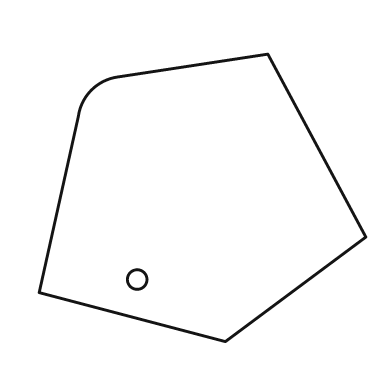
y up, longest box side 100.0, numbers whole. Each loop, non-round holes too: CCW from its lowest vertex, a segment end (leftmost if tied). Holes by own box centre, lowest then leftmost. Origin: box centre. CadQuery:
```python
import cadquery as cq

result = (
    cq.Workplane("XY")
    .moveTo(7.0, -44.0)
    .lineTo(50.0, -12.0)
    .lineTo(20.0, 44.0)
    .lineTo(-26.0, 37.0)
    .threePointArc((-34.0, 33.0), (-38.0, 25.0))
    .lineTo(-50.0, -29.0)
    .close()
    .moveTo(-20.0, -25.0)
    .circle(3.0)
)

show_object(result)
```